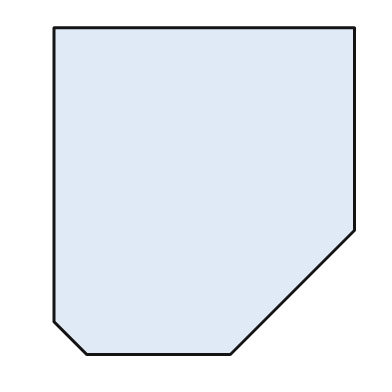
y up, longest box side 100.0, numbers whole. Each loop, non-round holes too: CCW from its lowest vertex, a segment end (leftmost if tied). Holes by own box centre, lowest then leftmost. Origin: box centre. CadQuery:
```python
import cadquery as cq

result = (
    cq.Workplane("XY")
    .moveTo(-36.0, -50.0)
    .lineTo(8.0, -50.0)
    .lineTo(46.0, -12.0)
    .lineTo(46.0, 50.0)
    .lineTo(-46.0, 50.0)
    .lineTo(-46.0, -40.0)
    .close()
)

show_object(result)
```